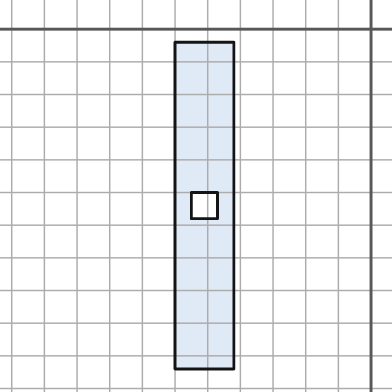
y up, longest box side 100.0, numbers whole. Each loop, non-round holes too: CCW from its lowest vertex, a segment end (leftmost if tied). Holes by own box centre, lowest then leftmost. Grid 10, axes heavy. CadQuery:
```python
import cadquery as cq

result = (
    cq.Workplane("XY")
    .moveTo(-60.0, -104.0)
    .lineTo(-42.0, -104.0)
    .lineTo(-42.0, -4.0)
    .lineTo(-60.0, -4.0)
    .close()
    .moveTo(-55.0, -58.0)
    .lineTo(-47.0, -58.0)
    .lineTo(-47.0, -50.0)
    .lineTo(-55.0, -50.0)
    .close()
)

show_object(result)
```